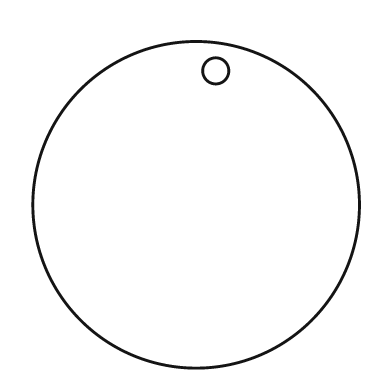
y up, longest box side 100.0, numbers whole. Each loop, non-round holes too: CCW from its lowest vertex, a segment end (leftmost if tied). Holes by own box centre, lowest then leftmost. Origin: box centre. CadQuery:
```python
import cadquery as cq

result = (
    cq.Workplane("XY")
    .moveTo(0.0, 0.0)
    .circle(50.0)
    .moveTo(6.0, 41.0)
    .circle(4.0)
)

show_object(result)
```